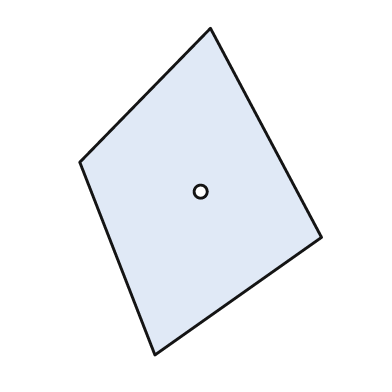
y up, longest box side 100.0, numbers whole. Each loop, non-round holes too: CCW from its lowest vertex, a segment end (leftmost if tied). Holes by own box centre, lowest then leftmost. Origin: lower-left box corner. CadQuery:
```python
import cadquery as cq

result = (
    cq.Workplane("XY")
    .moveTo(23.0, 0.0)
    .lineTo(74.0, 36.0)
    .lineTo(40.0, 100.0)
    .lineTo(0.0, 59.0)
    .close()
    .moveTo(37.0, 50.0)
    .circle(2.0)
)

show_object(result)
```